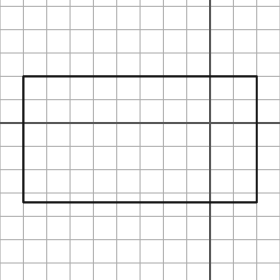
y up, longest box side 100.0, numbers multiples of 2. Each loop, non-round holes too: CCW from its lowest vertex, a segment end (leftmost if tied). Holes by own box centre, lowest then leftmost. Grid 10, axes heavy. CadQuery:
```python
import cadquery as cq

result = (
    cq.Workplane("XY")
    .moveTo(-80.0, -34.0)
    .lineTo(20.0, -34.0)
    .lineTo(20.0, 20.0)
    .lineTo(-80.0, 20.0)
    .close()
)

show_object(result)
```